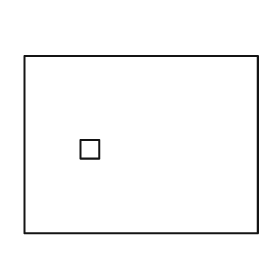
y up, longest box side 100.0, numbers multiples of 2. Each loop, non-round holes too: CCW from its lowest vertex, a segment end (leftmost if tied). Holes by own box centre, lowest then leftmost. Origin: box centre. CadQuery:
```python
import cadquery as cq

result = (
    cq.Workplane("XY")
    .moveTo(-50.0, -38.0)
    .lineTo(50.0, -38.0)
    .lineTo(50.0, 38.0)
    .lineTo(-50.0, 38.0)
    .close()
    .moveTo(-26.0, -6.0)
    .lineTo(-18.0, -6.0)
    .lineTo(-18.0, 2.0)
    .lineTo(-26.0, 2.0)
    .close()
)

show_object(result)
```